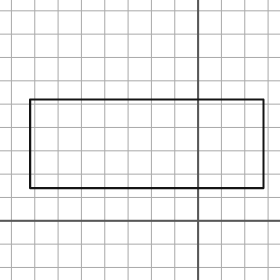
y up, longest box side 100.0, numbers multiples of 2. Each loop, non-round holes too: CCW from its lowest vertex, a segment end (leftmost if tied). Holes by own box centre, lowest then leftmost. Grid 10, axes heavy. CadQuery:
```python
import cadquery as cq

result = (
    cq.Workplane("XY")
    .moveTo(-72.0, 14.0)
    .lineTo(28.0, 14.0)
    .lineTo(28.0, 52.0)
    .lineTo(-72.0, 52.0)
    .close()
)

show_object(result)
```